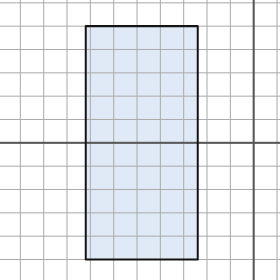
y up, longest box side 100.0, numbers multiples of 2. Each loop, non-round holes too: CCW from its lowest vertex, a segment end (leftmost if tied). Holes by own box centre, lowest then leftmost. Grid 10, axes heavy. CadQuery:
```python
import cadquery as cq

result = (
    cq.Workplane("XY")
    .moveTo(-72.0, -50.0)
    .lineTo(-24.0, -50.0)
    .lineTo(-24.0, 50.0)
    .lineTo(-72.0, 50.0)
    .close()
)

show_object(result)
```